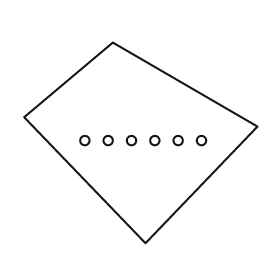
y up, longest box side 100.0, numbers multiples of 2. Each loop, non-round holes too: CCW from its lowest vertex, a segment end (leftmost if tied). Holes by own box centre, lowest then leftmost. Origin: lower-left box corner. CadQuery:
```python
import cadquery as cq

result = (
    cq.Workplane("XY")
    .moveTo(52.0, 0.0)
    .lineTo(100.0, 50.0)
    .lineTo(38.0, 86.0)
    .lineTo(0.0, 54.0)
    .close()
    .moveTo(26.0, 44.0)
    .circle(2.0)
    .moveTo(36.0, 44.0)
    .circle(2.0)
    .moveTo(46.0, 44.0)
    .circle(2.0)
    .moveTo(56.0, 44.0)
    .circle(2.0)
    .moveTo(66.0, 44.0)
    .circle(2.0)
    .moveTo(76.0, 44.0)
    .circle(2.0)
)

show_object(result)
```